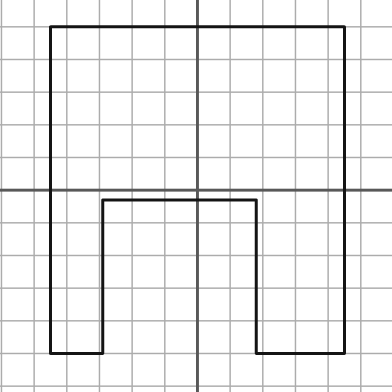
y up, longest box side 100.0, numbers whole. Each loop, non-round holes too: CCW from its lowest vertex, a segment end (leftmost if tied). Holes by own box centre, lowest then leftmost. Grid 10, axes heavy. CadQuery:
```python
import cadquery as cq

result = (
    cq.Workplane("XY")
    .moveTo(-45.0, -50.0)
    .lineTo(-29.0, -50.0)
    .lineTo(-29.0, -3.0)
    .lineTo(18.0, -3.0)
    .lineTo(18.0, -50.0)
    .lineTo(45.0, -50.0)
    .lineTo(45.0, 50.0)
    .lineTo(-45.0, 50.0)
    .close()
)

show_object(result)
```